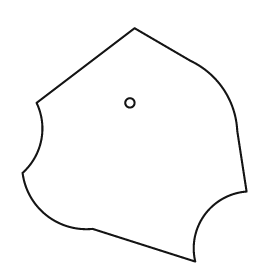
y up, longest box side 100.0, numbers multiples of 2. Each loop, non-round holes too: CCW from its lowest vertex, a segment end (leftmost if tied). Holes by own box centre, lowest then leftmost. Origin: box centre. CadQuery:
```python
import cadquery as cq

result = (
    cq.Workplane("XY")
    .moveTo(26.0, -50.0)
    .threePointArc((30.0, -30.0), (48.0, -20.0))
    .lineTo(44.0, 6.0)
    .threePointArc((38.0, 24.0), (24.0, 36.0))
    .lineTo(0.0, 50.0)
    .lineTo(-42.0, 18.0)
    .threePointArc((-40.0, 2.0), (-48.0, -12.0))
    .threePointArc((-38.0, -30.0), (-18.0, -36.0))
    .close()
    .moveTo(-2.0, 18.0)
    .circle(2.0)
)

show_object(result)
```